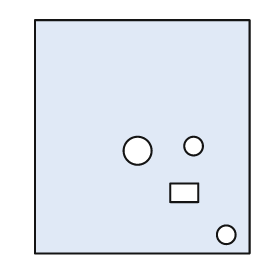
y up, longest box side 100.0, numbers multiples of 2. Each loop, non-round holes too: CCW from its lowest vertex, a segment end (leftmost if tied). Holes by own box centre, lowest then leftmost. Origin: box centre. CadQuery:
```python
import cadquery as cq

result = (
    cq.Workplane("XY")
    .moveTo(-46.0, -50.0)
    .lineTo(46.0, -50.0)
    .lineTo(46.0, 50.0)
    .lineTo(-46.0, 50.0)
    .close()
    .moveTo(36.0, -42.0)
    .circle(4.0)
    .moveTo(12.0, -28.0)
    .lineTo(24.0, -28.0)
    .lineTo(24.0, -20.0)
    .lineTo(12.0, -20.0)
    .close()
    .moveTo(-2.0, -6.0)
    .circle(6.0)
    .moveTo(22.0, -4.0)
    .circle(4.0)
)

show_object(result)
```